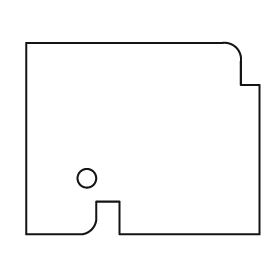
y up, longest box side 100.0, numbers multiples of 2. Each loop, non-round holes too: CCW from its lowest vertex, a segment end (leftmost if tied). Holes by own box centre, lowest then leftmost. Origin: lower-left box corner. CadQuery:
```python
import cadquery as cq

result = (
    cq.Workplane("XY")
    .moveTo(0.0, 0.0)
    .lineTo(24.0, 0.0)
    .threePointArc((28.0, 2.0), (30.0, 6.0))
    .lineTo(30.0, 14.0)
    .lineTo(40.0, 14.0)
    .lineTo(40.0, 0.0)
    .lineTo(100.0, 0.0)
    .lineTo(100.0, 64.0)
    .lineTo(92.0, 64.0)
    .lineTo(92.0, 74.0)
    .threePointArc((90.0, 80.0), (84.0, 82.0))
    .lineTo(0.0, 82.0)
    .close()
    .moveTo(26.0, 24.0)
    .circle(4.0)
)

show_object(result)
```